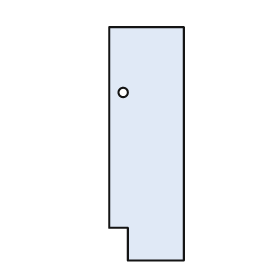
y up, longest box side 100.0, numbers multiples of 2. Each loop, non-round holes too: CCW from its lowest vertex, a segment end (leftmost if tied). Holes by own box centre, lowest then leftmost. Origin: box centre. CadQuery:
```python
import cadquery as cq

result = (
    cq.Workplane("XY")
    .moveTo(-8.0, -50.0)
    .lineTo(16.0, -50.0)
    .lineTo(16.0, 50.0)
    .lineTo(-16.0, 50.0)
    .lineTo(-16.0, -36.0)
    .lineTo(-8.0, -36.0)
    .close()
    .moveTo(-10.0, 22.0)
    .circle(2.0)
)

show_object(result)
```